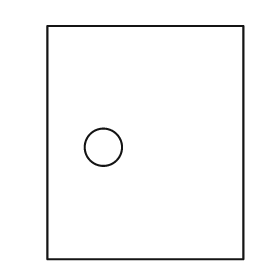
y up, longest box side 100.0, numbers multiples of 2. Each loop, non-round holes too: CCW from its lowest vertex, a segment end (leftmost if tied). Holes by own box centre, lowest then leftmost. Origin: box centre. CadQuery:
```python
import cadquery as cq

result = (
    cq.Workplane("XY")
    .moveTo(-42.0, -50.0)
    .lineTo(42.0, -50.0)
    .lineTo(42.0, 50.0)
    .lineTo(-42.0, 50.0)
    .close()
    .moveTo(-18.0, -2.0)
    .circle(8.0)
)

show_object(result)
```